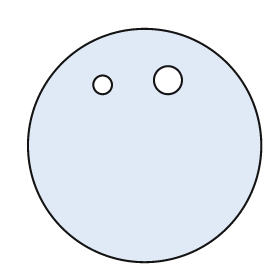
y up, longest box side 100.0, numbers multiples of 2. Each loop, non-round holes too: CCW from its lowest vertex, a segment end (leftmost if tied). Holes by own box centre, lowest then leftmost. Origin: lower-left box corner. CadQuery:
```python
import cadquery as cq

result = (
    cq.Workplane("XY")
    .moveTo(50.0, 50.0)
    .circle(50.0)
    .moveTo(32.0, 76.0)
    .circle(4.0)
    .moveTo(60.0, 78.0)
    .circle(6.0)
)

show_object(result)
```